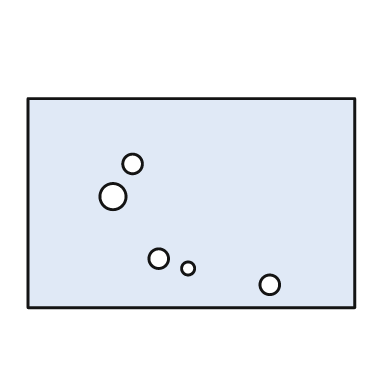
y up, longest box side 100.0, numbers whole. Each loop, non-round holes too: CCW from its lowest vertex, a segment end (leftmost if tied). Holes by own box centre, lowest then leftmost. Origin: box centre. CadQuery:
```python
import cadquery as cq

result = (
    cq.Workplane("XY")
    .moveTo(-50.0, -32.0)
    .lineTo(50.0, -32.0)
    .lineTo(50.0, 32.0)
    .lineTo(-50.0, 32.0)
    .close()
    .moveTo(24.0, -25.0)
    .circle(3.0)
    .moveTo(-1.0, -20.0)
    .circle(2.0)
    .moveTo(-10.0, -17.0)
    .circle(3.0)
    .moveTo(-24.0, 2.0)
    .circle(4.0)
    .moveTo(-18.0, 12.0)
    .circle(3.0)
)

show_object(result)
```